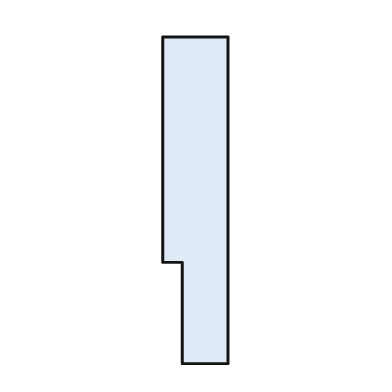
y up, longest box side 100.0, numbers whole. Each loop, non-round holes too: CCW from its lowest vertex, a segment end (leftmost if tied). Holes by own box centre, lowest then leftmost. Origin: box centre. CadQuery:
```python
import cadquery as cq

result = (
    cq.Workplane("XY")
    .moveTo(-4.0, -50.0)
    .lineTo(10.0, -50.0)
    .lineTo(10.0, 50.0)
    .lineTo(-10.0, 50.0)
    .lineTo(-10.0, -19.0)
    .lineTo(-4.0, -19.0)
    .close()
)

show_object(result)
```